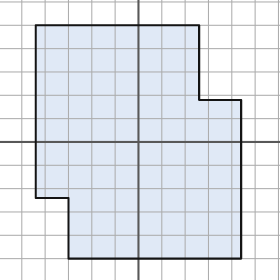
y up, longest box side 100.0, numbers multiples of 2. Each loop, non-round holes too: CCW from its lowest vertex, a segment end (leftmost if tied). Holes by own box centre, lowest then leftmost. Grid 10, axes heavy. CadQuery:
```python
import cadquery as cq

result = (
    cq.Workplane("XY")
    .moveTo(-30.0, -50.0)
    .lineTo(44.0, -50.0)
    .lineTo(44.0, 18.0)
    .lineTo(26.0, 18.0)
    .lineTo(26.0, 50.0)
    .lineTo(-44.0, 50.0)
    .lineTo(-44.0, -24.0)
    .lineTo(-30.0, -24.0)
    .close()
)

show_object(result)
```